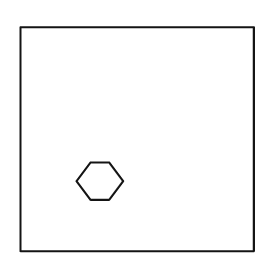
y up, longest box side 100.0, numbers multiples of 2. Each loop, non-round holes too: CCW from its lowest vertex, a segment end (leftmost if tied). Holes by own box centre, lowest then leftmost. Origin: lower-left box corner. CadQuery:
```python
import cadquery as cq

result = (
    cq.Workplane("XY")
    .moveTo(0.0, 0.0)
    .lineTo(100.0, 0.0)
    .lineTo(100.0, 96.0)
    .lineTo(0.0, 96.0)
    .close()
    .moveTo(30.0, 22.0)
    .lineTo(38.0, 22.0)
    .lineTo(44.0, 30.0)
    .lineTo(38.0, 38.0)
    .lineTo(30.0, 38.0)
    .lineTo(24.0, 30.0)
    .close()
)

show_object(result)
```